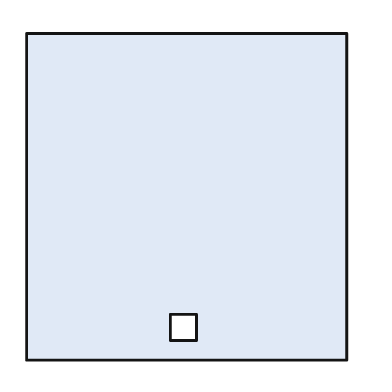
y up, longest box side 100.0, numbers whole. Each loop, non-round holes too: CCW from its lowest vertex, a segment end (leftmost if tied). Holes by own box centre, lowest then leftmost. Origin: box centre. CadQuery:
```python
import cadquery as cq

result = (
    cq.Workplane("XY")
    .moveTo(-49.0, -50.0)
    .lineTo(49.0, -50.0)
    .lineTo(49.0, 50.0)
    .lineTo(-49.0, 50.0)
    .close()
    .moveTo(-5.0, -44.0)
    .lineTo(3.0, -44.0)
    .lineTo(3.0, -36.0)
    .lineTo(-5.0, -36.0)
    .close()
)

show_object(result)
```